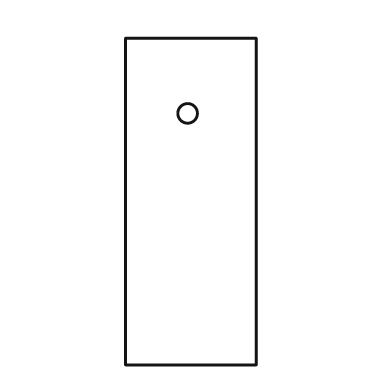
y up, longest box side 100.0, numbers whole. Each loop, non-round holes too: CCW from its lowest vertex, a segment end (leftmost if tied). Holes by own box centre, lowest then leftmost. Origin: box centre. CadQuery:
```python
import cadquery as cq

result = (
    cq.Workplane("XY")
    .moveTo(-20.0, -50.0)
    .lineTo(20.0, -50.0)
    .lineTo(20.0, 50.0)
    .lineTo(-20.0, 50.0)
    .close()
    .moveTo(-1.0, 27.0)
    .circle(3.0)
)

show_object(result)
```